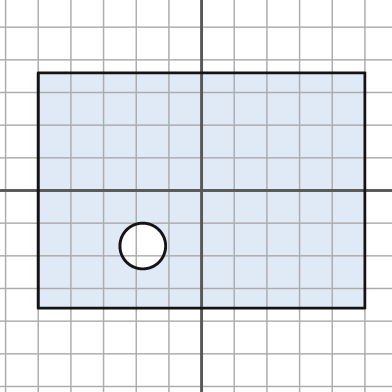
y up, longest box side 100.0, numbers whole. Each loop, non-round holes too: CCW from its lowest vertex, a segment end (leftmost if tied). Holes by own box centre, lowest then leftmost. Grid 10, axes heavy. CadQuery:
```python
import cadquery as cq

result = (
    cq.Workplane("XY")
    .moveTo(-50.0, -36.0)
    .lineTo(50.0, -36.0)
    .lineTo(50.0, 36.0)
    .lineTo(-50.0, 36.0)
    .close()
    .moveTo(-18.0, -17.0)
    .circle(7.0)
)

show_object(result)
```